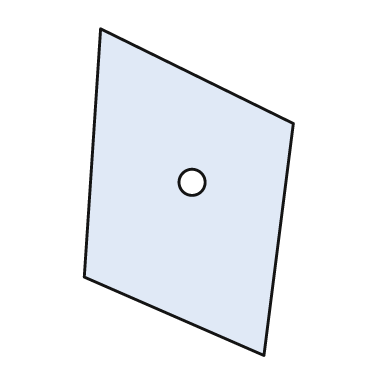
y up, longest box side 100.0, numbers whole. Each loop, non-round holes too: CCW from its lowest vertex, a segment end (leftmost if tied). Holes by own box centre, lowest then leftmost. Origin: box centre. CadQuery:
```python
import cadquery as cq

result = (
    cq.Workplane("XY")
    .moveTo(23.0, -50.0)
    .lineTo(32.0, 21.0)
    .lineTo(-27.0, 50.0)
    .lineTo(-32.0, -26.0)
    .close()
    .moveTo(1.0, 3.0)
    .circle(4.0)
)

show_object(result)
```